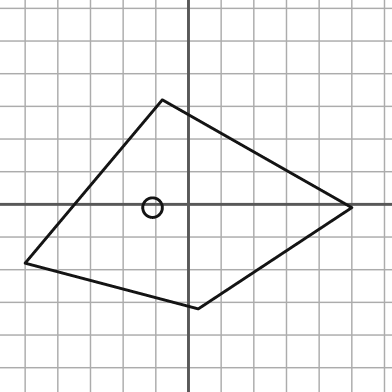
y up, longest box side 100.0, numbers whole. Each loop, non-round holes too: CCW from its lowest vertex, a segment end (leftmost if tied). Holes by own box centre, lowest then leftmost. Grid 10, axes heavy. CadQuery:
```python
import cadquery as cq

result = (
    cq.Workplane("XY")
    .moveTo(3.0, -32.0)
    .lineTo(50.0, -1.0)
    .lineTo(-8.0, 32.0)
    .lineTo(-50.0, -18.0)
    .close()
    .moveTo(-11.0, -1.0)
    .circle(3.0)
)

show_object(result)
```